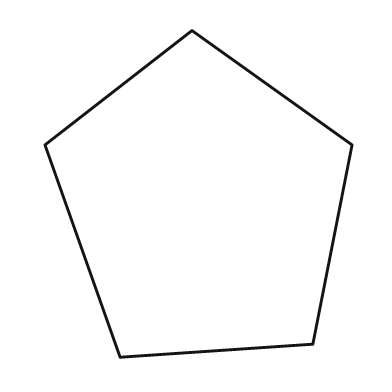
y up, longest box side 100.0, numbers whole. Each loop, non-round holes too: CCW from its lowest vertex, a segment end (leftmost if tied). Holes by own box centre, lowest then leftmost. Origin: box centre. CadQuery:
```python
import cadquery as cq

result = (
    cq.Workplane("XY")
    .moveTo(-24.0, -50.0)
    .lineTo(35.0, -46.0)
    .lineTo(47.0, 15.0)
    .lineTo(-2.0, 50.0)
    .lineTo(-47.0, 15.0)
    .close()
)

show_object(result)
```